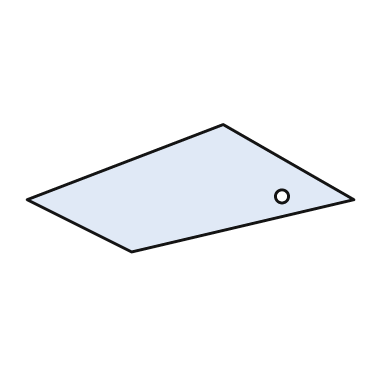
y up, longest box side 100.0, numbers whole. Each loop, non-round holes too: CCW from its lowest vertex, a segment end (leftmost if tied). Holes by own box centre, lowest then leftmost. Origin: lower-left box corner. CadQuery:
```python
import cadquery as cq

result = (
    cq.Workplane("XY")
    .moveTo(32.0, 0.0)
    .lineTo(100.0, 16.0)
    .lineTo(60.0, 39.0)
    .lineTo(0.0, 16.0)
    .close()
    .moveTo(78.0, 17.0)
    .circle(2.0)
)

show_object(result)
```